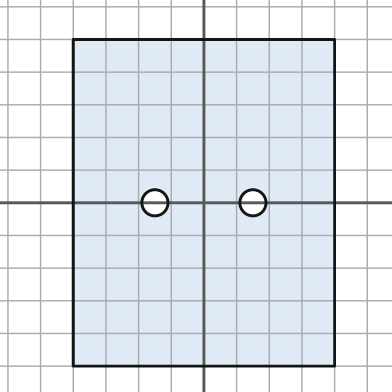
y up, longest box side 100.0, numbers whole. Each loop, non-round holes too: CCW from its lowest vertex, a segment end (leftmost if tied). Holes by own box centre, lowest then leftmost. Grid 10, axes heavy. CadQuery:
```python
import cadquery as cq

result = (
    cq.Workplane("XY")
    .moveTo(-40.0, -50.0)
    .lineTo(40.0, -50.0)
    .lineTo(40.0, 50.0)
    .lineTo(-40.0, 50.0)
    .close()
    .moveTo(-15.0, 0.0)
    .circle(4.0)
    .moveTo(15.0, 0.0)
    .circle(4.0)
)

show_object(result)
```